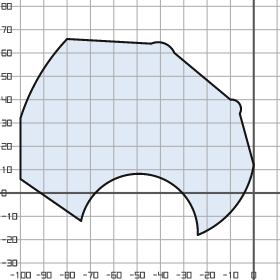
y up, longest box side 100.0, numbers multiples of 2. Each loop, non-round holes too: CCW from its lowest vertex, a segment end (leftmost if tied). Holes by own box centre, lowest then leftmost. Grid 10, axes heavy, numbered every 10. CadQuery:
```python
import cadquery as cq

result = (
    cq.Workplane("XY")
    .moveTo(-24.0, -18.0)
    .threePointArc((-8.0, -6.0), (0.0, 12.0))
    .lineTo(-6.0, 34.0)
    .threePointArc((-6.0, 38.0), (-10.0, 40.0))
    .lineTo(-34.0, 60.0)
    .threePointArc((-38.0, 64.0), (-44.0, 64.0))
    .lineTo(-80.0, 66.0)
    .threePointArc((-92.0, 50.0), (-100.0, 32.0))
    .lineTo(-100.0, 6.0)
    .lineTo(-74.0, -12.0)
    .threePointArc((-46.0, 8.0), (-24.0, -18.0))
    .close()
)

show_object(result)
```